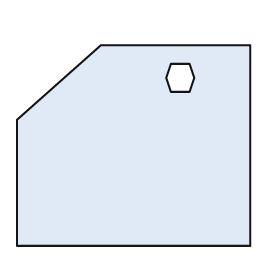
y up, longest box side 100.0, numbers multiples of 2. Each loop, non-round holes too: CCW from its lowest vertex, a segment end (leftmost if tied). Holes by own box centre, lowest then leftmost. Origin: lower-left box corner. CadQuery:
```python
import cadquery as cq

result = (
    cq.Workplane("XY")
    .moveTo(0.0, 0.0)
    .lineTo(100.0, 0.0)
    .lineTo(100.0, 86.0)
    .lineTo(36.0, 86.0)
    .lineTo(0.0, 54.0)
    .close()
    .moveTo(66.0, 66.0)
    .lineTo(74.0, 66.0)
    .lineTo(76.0, 72.0)
    .lineTo(74.0, 78.0)
    .lineTo(66.0, 78.0)
    .lineTo(64.0, 72.0)
    .close()
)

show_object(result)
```